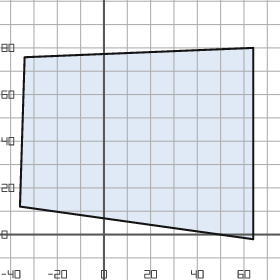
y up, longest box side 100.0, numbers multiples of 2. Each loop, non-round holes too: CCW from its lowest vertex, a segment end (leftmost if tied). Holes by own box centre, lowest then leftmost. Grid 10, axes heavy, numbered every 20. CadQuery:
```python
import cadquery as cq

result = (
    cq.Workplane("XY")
    .moveTo(64.0, -2.0)
    .lineTo(64.0, 80.0)
    .lineTo(-34.0, 76.0)
    .lineTo(-36.0, 12.0)
    .close()
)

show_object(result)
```